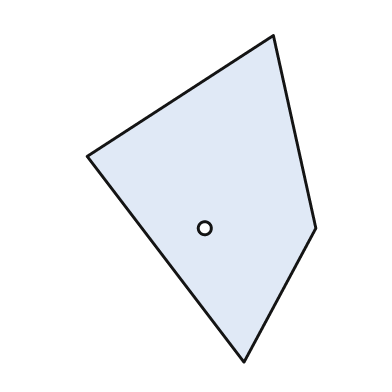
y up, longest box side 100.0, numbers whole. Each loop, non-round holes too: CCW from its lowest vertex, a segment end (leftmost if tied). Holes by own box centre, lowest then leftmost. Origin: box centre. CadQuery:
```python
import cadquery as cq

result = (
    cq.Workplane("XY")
    .moveTo(13.0, -50.0)
    .lineTo(35.0, -9.0)
    .lineTo(22.0, 50.0)
    .lineTo(-35.0, 13.0)
    .close()
    .moveTo(1.0, -9.0)
    .circle(2.0)
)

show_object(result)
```